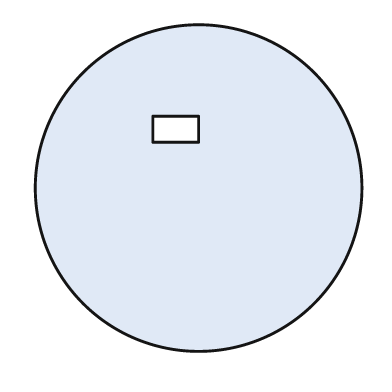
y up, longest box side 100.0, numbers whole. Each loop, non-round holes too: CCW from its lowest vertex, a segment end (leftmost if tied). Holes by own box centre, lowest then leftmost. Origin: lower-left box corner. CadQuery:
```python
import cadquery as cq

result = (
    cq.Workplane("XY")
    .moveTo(50.0, 50.0)
    .circle(50.0)
    .moveTo(36.0, 64.0)
    .lineTo(50.0, 64.0)
    .lineTo(50.0, 72.0)
    .lineTo(36.0, 72.0)
    .close()
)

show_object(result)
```